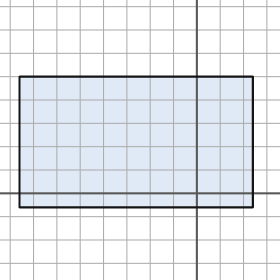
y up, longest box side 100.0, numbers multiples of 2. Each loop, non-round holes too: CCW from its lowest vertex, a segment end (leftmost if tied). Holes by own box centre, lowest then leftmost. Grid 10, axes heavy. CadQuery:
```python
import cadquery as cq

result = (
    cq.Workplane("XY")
    .moveTo(-76.0, -6.0)
    .lineTo(24.0, -6.0)
    .lineTo(24.0, 50.0)
    .lineTo(-76.0, 50.0)
    .close()
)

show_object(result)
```